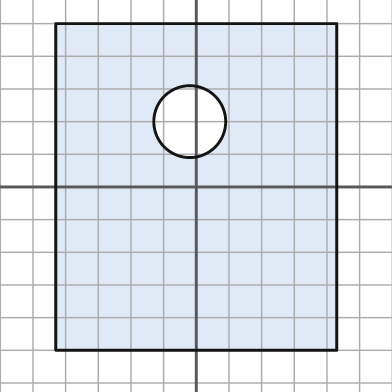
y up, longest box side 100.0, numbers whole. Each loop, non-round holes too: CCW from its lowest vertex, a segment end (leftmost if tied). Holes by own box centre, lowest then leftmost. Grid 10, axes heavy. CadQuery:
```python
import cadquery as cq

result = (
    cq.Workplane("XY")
    .moveTo(-43.0, -50.0)
    .lineTo(43.0, -50.0)
    .lineTo(43.0, 50.0)
    .lineTo(-43.0, 50.0)
    .close()
    .moveTo(-2.0, 20.0)
    .circle(11.0)
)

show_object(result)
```